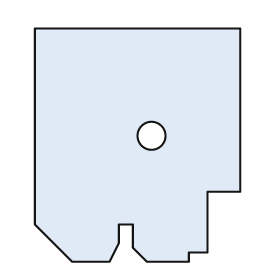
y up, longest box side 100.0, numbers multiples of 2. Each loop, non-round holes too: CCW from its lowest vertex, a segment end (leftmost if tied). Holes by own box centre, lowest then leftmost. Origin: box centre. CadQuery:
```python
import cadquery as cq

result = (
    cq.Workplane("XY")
    .moveTo(-28.0, -50.0)
    .lineTo(-12.0, -50.0)
    .lineTo(-8.0, -42.0)
    .lineTo(-8.0, -34.0)
    .lineTo(-2.0, -34.0)
    .lineTo(-2.0, -44.0)
    .lineTo(4.0, -50.0)
    .lineTo(22.0, -50.0)
    .lineTo(22.0, -46.0)
    .lineTo(30.0, -46.0)
    .lineTo(30.0, -20.0)
    .lineTo(44.0, -20.0)
    .lineTo(44.0, 50.0)
    .lineTo(-44.0, 50.0)
    .lineTo(-44.0, -34.0)
    .close()
    .moveTo(6.0, 4.0)
    .circle(6.0)
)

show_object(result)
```